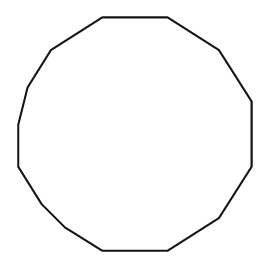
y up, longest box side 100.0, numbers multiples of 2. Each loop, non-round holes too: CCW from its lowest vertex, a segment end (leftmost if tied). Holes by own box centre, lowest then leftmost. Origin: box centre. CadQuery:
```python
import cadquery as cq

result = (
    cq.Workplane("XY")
    .moveTo(-14.0, -50.0)
    .lineTo(14.0, -50.0)
    .lineTo(36.0, -36.0)
    .lineTo(50.0, -14.0)
    .lineTo(50.0, 14.0)
    .lineTo(36.0, 36.0)
    .lineTo(14.0, 50.0)
    .lineTo(-14.0, 50.0)
    .lineTo(-36.0, 36.0)
    .lineTo(-46.0, 20.0)
    .lineTo(-50.0, 4.0)
    .lineTo(-50.0, -14.0)
    .lineTo(-40.0, -30.0)
    .lineTo(-30.0, -40.0)
    .close()
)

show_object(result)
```